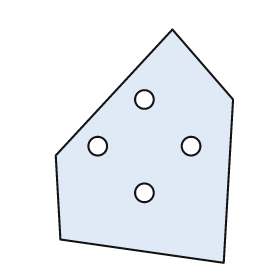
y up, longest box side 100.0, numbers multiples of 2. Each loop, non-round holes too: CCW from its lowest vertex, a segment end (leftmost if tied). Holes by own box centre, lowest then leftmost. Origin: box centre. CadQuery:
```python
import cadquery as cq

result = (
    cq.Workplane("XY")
    .moveTo(34.0, -50.0)
    .lineTo(38.0, 20.0)
    .lineTo(12.0, 50.0)
    .lineTo(-38.0, -4.0)
    .lineTo(-36.0, -40.0)
    .close()
    .moveTo(0.0, -20.0)
    .circle(4.0)
    .moveTo(-20.0, 0.0)
    .circle(4.0)
    .moveTo(20.0, 0.0)
    .circle(4.0)
    .moveTo(0.0, 20.0)
    .circle(4.0)
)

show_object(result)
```